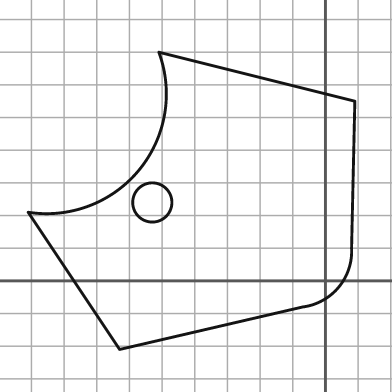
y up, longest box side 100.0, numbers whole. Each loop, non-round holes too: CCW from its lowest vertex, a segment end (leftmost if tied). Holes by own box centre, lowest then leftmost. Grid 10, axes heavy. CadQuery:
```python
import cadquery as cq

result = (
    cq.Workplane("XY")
    .moveTo(-63.0, -21.0)
    .lineTo(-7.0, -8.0)
    .threePointArc((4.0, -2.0), (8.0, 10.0))
    .lineTo(9.0, 55.0)
    .lineTo(-51.0, 70.0)
    .threePointArc((-57.0, 34.0), (-91.0, 21.0))
    .close()
    .moveTo(-53.0, 24.0)
    .circle(6.0)
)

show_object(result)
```